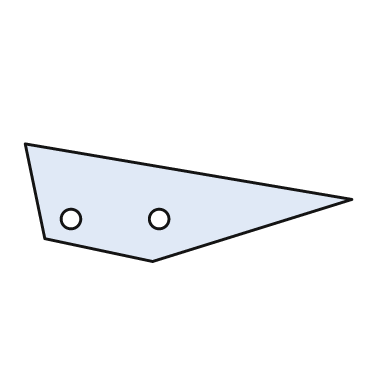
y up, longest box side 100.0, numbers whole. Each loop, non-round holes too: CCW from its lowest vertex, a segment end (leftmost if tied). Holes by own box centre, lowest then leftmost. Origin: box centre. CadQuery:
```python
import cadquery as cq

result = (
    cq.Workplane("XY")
    .moveTo(-11.0, -18.0)
    .lineTo(50.0, 1.0)
    .lineTo(-50.0, 18.0)
    .lineTo(-44.0, -11.0)
    .close()
    .moveTo(-36.0, -5.0)
    .circle(3.0)
    .moveTo(-9.0, -5.0)
    .circle(3.0)
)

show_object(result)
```